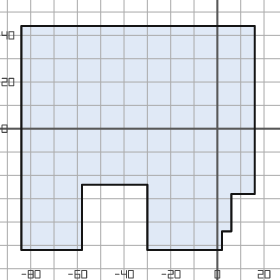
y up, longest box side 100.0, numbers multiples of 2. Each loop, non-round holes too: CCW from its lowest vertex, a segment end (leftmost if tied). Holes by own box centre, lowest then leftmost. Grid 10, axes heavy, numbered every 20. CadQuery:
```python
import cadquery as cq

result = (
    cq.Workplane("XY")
    .moveTo(-84.0, -52.0)
    .lineTo(-58.0, -52.0)
    .lineTo(-58.0, -24.0)
    .lineTo(-30.0, -24.0)
    .lineTo(-30.0, -52.0)
    .lineTo(2.0, -52.0)
    .lineTo(2.0, -44.0)
    .lineTo(6.0, -44.0)
    .lineTo(6.0, -28.0)
    .lineTo(16.0, -28.0)
    .lineTo(16.0, 44.0)
    .lineTo(-84.0, 44.0)
    .close()
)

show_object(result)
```